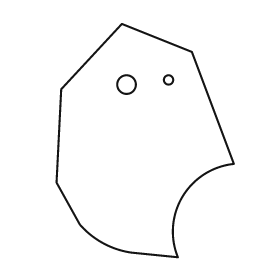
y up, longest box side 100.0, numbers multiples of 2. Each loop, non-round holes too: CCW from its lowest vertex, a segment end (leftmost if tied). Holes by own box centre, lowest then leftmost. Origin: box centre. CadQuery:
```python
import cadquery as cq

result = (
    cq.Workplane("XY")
    .moveTo(14.0, -50.0)
    .threePointArc((16.0, -24.0), (38.0, -10.0))
    .lineTo(20.0, 38.0)
    .lineTo(-10.0, 50.0)
    .lineTo(-36.0, 22.0)
    .lineTo(-38.0, -18.0)
    .lineTo(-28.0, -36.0)
    .threePointArc((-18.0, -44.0), (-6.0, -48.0))
    .close()
    .moveTo(-8.0, 24.0)
    .circle(4.0)
    .moveTo(10.0, 26.0)
    .circle(2.0)
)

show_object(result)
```